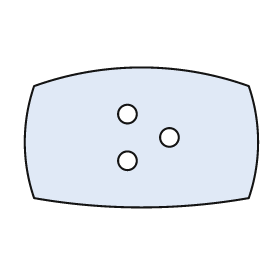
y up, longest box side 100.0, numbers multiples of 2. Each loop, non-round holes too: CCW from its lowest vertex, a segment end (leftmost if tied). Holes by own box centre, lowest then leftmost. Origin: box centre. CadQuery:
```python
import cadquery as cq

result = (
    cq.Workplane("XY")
    .moveTo(-46.0, -26.0)
    .threePointArc((0.0, -30.0), (46.0, -26.0))
    .threePointArc((50.0, -2.0), (46.0, 22.0))
    .threePointArc((0.0, 30.0), (-46.0, 22.0))
    .threePointArc((-50.0, -2.0), (-46.0, -26.0))
    .close()
    .moveTo(-6.0, -10.0)
    .circle(4.0)
    .moveTo(12.0, 0.0)
    .circle(4.0)
    .moveTo(-6.0, 10.0)
    .circle(4.0)
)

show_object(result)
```